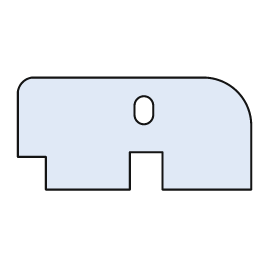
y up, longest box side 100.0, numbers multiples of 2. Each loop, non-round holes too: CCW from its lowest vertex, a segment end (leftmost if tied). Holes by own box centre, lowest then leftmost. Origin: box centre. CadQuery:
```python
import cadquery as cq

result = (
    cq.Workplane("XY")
    .moveTo(-38.0, -24.0)
    .lineTo(-2.0, -24.0)
    .lineTo(-2.0, -8.0)
    .lineTo(12.0, -8.0)
    .lineTo(12.0, -24.0)
    .lineTo(50.0, -24.0)
    .lineTo(50.0, 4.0)
    .threePointArc((44.0, 18.0), (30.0, 24.0))
    .lineTo(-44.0, 24.0)
    .threePointArc((-48.0, 22.0), (-50.0, 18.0))
    .lineTo(-50.0, -10.0)
    .lineTo(-38.0, -10.0)
    .close()
    .moveTo(0.0, 8.0)
    .threePointArc((4.0, 4.0), (8.0, 8.0))
    .lineTo(8.0, 12.0)
    .threePointArc((4.0, 16.0), (0.0, 12.0))
    .close()
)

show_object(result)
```